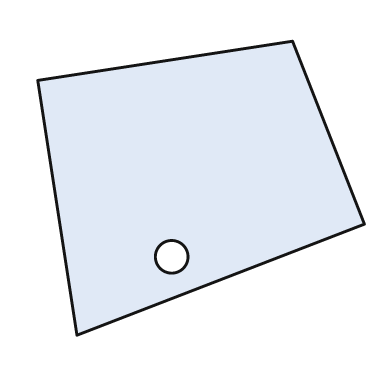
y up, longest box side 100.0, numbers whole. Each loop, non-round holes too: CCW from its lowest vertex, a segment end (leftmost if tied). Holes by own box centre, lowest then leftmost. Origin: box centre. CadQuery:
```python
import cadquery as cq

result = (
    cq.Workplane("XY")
    .moveTo(-38.0, -45.0)
    .lineTo(50.0, -11.0)
    .lineTo(28.0, 45.0)
    .lineTo(-50.0, 33.0)
    .close()
    .moveTo(-9.0, -21.0)
    .circle(5.0)
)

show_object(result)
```